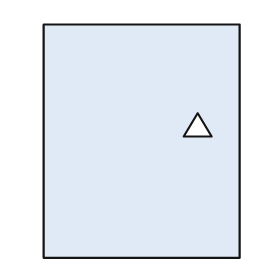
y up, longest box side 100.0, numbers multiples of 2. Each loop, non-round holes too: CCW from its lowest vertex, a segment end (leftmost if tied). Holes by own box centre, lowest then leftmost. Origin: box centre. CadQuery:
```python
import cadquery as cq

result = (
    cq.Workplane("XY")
    .moveTo(-42.0, -50.0)
    .lineTo(42.0, -50.0)
    .lineTo(42.0, 50.0)
    .lineTo(-42.0, 50.0)
    .close()
    .moveTo(18.0, 2.0)
    .lineTo(30.0, 2.0)
    .lineTo(24.0, 12.0)
    .close()
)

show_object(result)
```